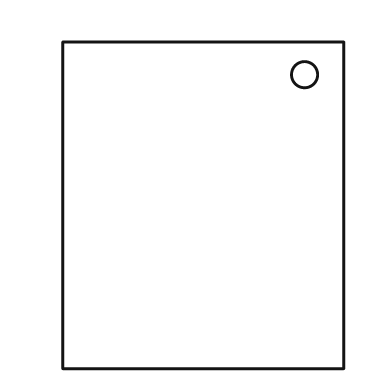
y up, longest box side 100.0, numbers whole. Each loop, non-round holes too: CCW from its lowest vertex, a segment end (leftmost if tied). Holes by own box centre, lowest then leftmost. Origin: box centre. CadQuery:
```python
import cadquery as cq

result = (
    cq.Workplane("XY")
    .moveTo(-43.0, -50.0)
    .lineTo(43.0, -50.0)
    .lineTo(43.0, 50.0)
    .lineTo(-43.0, 50.0)
    .close()
    .moveTo(31.0, 40.0)
    .circle(4.0)
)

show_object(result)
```